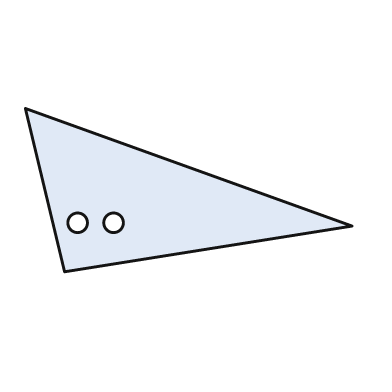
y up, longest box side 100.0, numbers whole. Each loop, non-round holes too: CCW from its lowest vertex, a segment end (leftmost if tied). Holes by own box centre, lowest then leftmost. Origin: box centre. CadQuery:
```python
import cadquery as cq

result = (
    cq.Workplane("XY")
    .moveTo(-38.0, -25.0)
    .lineTo(50.0, -11.0)
    .lineTo(-50.0, 25.0)
    .close()
    .moveTo(-34.0, -10.0)
    .circle(3.0)
    .moveTo(-23.0, -10.0)
    .circle(3.0)
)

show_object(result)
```